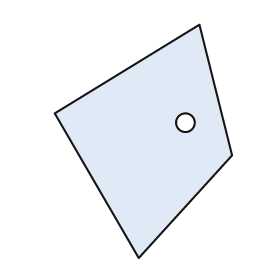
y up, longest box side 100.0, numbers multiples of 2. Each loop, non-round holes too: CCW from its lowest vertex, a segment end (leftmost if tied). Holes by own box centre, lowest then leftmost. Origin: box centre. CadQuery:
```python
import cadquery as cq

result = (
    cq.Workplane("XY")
    .moveTo(-2.0, -50.0)
    .lineTo(38.0, -6.0)
    .lineTo(24.0, 50.0)
    .lineTo(-38.0, 12.0)
    .close()
    .moveTo(18.0, 8.0)
    .circle(4.0)
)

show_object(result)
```